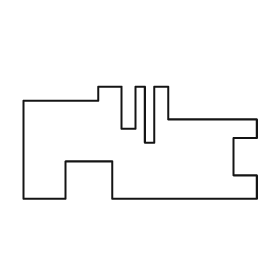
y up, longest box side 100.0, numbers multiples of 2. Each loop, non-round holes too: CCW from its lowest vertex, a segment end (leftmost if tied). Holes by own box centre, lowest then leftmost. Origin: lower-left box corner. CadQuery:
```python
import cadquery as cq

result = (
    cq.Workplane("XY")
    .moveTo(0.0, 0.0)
    .lineTo(18.0, 0.0)
    .lineTo(18.0, 16.0)
    .lineTo(38.0, 16.0)
    .lineTo(38.0, 0.0)
    .lineTo(100.0, 0.0)
    .lineTo(100.0, 10.0)
    .lineTo(90.0, 10.0)
    .lineTo(90.0, 26.0)
    .lineTo(100.0, 26.0)
    .lineTo(100.0, 34.0)
    .lineTo(62.0, 34.0)
    .lineTo(62.0, 48.0)
    .lineTo(56.0, 48.0)
    .lineTo(56.0, 24.0)
    .lineTo(52.0, 24.0)
    .lineTo(52.0, 48.0)
    .lineTo(48.0, 48.0)
    .lineTo(48.0, 30.0)
    .lineTo(42.0, 30.0)
    .lineTo(42.0, 48.0)
    .lineTo(32.0, 48.0)
    .lineTo(32.0, 42.0)
    .lineTo(0.0, 42.0)
    .close()
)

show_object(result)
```